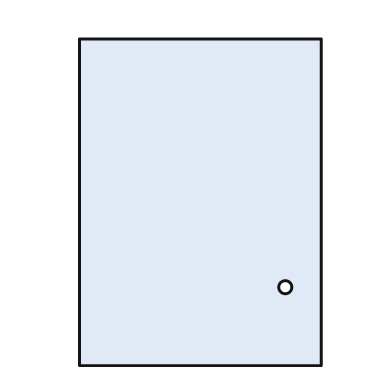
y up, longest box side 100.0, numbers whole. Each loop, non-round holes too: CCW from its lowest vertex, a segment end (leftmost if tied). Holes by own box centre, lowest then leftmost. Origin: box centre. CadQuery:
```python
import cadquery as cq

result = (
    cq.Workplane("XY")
    .moveTo(-37.0, -50.0)
    .lineTo(37.0, -50.0)
    .lineTo(37.0, 50.0)
    .lineTo(-37.0, 50.0)
    .close()
    .moveTo(26.0, -26.0)
    .circle(2.0)
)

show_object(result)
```